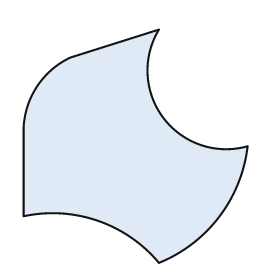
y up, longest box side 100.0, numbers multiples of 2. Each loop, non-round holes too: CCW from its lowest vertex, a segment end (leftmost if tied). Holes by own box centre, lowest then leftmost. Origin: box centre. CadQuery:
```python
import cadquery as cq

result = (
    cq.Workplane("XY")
    .moveTo(10.0, -50.0)
    .threePointArc((36.0, -30.0), (48.0, 0.0))
    .threePointArc((12.0, 12.0), (10.0, 50.0))
    .lineTo(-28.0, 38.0)
    .threePointArc((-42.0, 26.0), (-48.0, 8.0))
    .lineTo(-48.0, -30.0)
    .threePointArc((-16.0, -32.0), (10.0, -50.0))
    .close()
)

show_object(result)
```